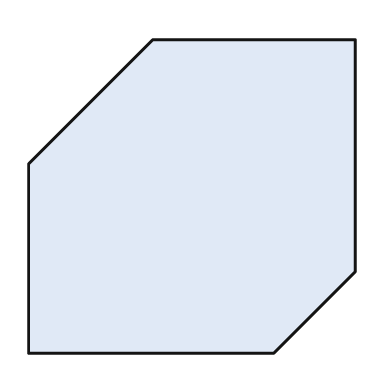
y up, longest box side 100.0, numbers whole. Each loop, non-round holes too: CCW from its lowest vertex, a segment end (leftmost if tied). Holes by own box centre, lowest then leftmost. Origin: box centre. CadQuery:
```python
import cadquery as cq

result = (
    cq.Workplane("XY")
    .moveTo(-50.0, -48.0)
    .lineTo(25.0, -48.0)
    .lineTo(50.0, -23.0)
    .lineTo(50.0, 48.0)
    .lineTo(-12.0, 48.0)
    .lineTo(-50.0, 10.0)
    .close()
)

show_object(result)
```